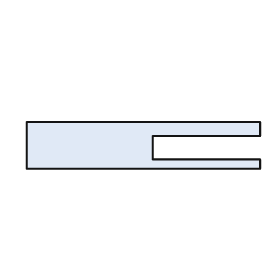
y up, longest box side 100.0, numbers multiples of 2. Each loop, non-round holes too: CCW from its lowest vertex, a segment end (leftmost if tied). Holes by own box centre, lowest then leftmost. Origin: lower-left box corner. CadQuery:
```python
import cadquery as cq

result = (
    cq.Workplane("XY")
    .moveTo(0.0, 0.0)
    .lineTo(100.0, 0.0)
    .lineTo(100.0, 4.0)
    .lineTo(54.0, 4.0)
    .lineTo(54.0, 14.0)
    .lineTo(100.0, 14.0)
    .lineTo(100.0, 20.0)
    .lineTo(0.0, 20.0)
    .close()
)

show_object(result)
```